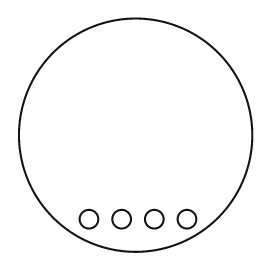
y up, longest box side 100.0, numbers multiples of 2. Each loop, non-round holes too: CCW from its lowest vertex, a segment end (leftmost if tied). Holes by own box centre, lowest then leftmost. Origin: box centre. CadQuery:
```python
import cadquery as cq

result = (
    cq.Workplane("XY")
    .moveTo(0.0, 0.0)
    .circle(50.0)
    .moveTo(-20.0, -36.0)
    .circle(4.0)
    .moveTo(-6.0, -36.0)
    .circle(4.0)
    .moveTo(8.0, -36.0)
    .circle(4.0)
    .moveTo(22.0, -36.0)
    .circle(4.0)
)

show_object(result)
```